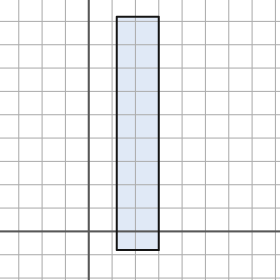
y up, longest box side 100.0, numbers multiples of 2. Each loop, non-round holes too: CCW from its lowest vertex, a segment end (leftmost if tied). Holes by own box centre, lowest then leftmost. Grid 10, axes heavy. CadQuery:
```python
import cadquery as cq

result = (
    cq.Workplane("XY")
    .moveTo(12.0, -8.0)
    .lineTo(30.0, -8.0)
    .lineTo(30.0, 92.0)
    .lineTo(12.0, 92.0)
    .close()
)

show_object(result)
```